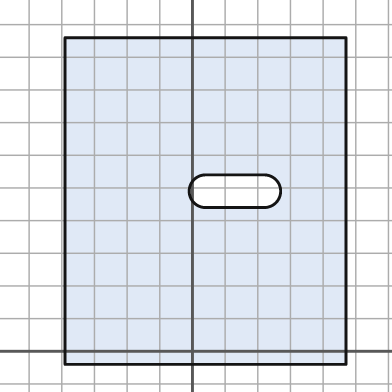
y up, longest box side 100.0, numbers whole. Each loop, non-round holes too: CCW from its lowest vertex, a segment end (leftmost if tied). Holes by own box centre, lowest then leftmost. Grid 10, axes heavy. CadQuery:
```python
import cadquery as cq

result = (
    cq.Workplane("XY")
    .moveTo(-39.0, -4.0)
    .lineTo(47.0, -4.0)
    .lineTo(47.0, 96.0)
    .lineTo(-39.0, 96.0)
    .close()
    .moveTo(4.0, 44.0)
    .lineTo(22.0, 44.0)
    .threePointArc((27.0, 49.0), (22.0, 54.0))
    .lineTo(4.0, 54.0)
    .threePointArc((-1.0, 49.0), (4.0, 44.0))
    .close()
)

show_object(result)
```